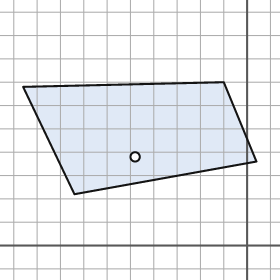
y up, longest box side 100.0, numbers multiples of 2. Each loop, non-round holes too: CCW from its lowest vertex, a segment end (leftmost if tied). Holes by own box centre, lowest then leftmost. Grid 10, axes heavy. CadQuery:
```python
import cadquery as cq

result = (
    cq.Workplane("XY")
    .moveTo(-74.0, 22.0)
    .lineTo(4.0, 36.0)
    .lineTo(-10.0, 70.0)
    .lineTo(-96.0, 68.0)
    .close()
    .moveTo(-48.0, 38.0)
    .circle(2.0)
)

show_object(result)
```